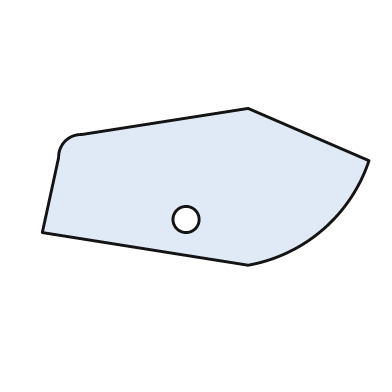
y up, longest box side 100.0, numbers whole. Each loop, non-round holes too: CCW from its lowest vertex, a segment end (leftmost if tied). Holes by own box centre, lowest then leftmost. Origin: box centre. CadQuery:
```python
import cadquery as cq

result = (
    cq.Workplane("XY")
    .moveTo(13.0, -24.0)
    .threePointArc((36.0, -13.0), (50.0, 8.0))
    .lineTo(13.0, 24.0)
    .lineTo(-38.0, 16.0)
    .threePointArc((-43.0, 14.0), (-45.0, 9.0))
    .lineTo(-50.0, -14.0)
    .close()
    .moveTo(-6.0, -10.0)
    .circle(4.0)
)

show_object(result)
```